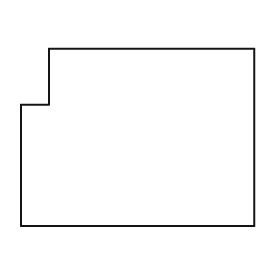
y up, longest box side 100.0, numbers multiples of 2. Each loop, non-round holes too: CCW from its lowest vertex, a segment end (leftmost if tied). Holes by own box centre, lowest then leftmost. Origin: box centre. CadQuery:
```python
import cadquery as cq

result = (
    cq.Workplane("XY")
    .moveTo(-50.0, -38.0)
    .lineTo(50.0, -38.0)
    .lineTo(50.0, 38.0)
    .lineTo(-38.0, 38.0)
    .lineTo(-38.0, 14.0)
    .lineTo(-50.0, 14.0)
    .close()
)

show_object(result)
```